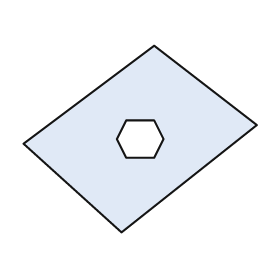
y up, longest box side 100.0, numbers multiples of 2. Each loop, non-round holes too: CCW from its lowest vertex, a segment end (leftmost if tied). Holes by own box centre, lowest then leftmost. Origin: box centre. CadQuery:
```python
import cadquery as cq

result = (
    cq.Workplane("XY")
    .moveTo(-8.0, -40.0)
    .lineTo(50.0, 6.0)
    .lineTo(6.0, 40.0)
    .lineTo(-50.0, -2.0)
    .close()
    .moveTo(-6.0, -8.0)
    .lineTo(6.0, -8.0)
    .lineTo(10.0, 0.0)
    .lineTo(6.0, 8.0)
    .lineTo(-6.0, 8.0)
    .lineTo(-10.0, 0.0)
    .close()
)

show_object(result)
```